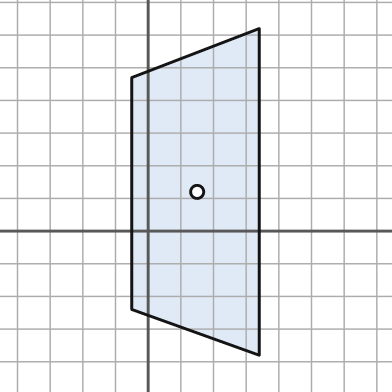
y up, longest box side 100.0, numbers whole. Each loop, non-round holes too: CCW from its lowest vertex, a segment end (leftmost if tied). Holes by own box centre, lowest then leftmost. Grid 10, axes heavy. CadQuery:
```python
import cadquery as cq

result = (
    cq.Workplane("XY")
    .moveTo(34.0, -38.0)
    .lineTo(34.0, 62.0)
    .lineTo(-5.0, 47.0)
    .lineTo(-5.0, -24.0)
    .close()
    .moveTo(15.0, 12.0)
    .circle(2.0)
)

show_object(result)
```